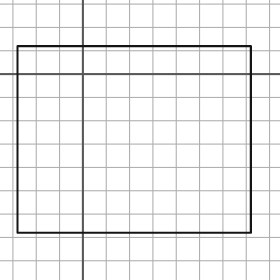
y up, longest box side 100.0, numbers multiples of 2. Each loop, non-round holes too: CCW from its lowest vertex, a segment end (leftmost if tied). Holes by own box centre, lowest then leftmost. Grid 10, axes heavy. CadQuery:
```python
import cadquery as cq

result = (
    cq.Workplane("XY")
    .moveTo(-28.0, -68.0)
    .lineTo(72.0, -68.0)
    .lineTo(72.0, 12.0)
    .lineTo(-28.0, 12.0)
    .close()
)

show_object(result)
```